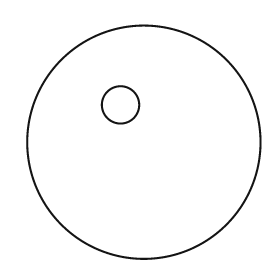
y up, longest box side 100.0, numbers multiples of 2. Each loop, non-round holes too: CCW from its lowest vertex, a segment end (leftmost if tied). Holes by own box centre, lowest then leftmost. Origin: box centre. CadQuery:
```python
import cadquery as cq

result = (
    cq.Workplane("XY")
    .moveTo(0.0, 0.0)
    .circle(50.0)
    .moveTo(-10.0, 16.0)
    .circle(8.0)
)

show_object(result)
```